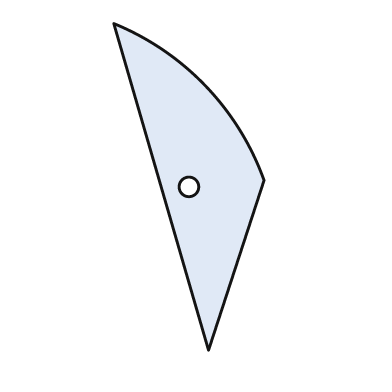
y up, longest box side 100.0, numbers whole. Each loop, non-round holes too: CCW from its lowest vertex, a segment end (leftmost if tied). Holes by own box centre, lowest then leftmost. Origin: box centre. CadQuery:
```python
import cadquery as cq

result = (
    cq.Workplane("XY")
    .moveTo(6.0, -50.0)
    .lineTo(23.0, 2.0)
    .threePointArc((5.0, 31.0), (-23.0, 50.0))
    .close()
    .moveTo(0.0, 0.0)
    .circle(3.0)
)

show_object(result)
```